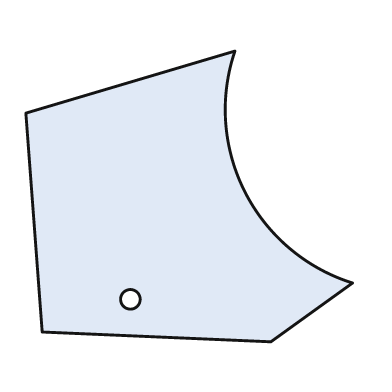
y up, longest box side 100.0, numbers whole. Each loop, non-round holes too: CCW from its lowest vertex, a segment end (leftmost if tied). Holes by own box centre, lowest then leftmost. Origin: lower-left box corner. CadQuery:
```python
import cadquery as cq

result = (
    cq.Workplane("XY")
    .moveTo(75.0, 0.0)
    .lineTo(100.0, 18.0)
    .threePointArc((67.0, 46.0), (64.0, 89.0))
    .lineTo(0.0, 70.0)
    .lineTo(5.0, 3.0)
    .close()
    .moveTo(32.0, 13.0)
    .circle(3.0)
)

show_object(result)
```